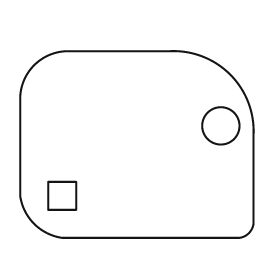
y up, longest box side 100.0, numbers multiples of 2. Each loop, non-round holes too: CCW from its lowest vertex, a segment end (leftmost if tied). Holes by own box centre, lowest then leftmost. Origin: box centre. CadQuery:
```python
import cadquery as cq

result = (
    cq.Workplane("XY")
    .moveTo(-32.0, -40.0)
    .lineTo(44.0, -40.0)
    .threePointArc((48.0, -38.0), (50.0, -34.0))
    .lineTo(50.0, 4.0)
    .threePointArc((40.0, 30.0), (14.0, 40.0))
    .lineTo(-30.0, 40.0)
    .threePointArc((-44.0, 34.0), (-50.0, 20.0))
    .lineTo(-50.0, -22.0)
    .threePointArc((-44.0, -34.0), (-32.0, -40.0))
    .close()
    .moveTo(-38.0, -28.0)
    .lineTo(-26.0, -28.0)
    .lineTo(-26.0, -16.0)
    .lineTo(-38.0, -16.0)
    .close()
    .moveTo(36.0, 8.0)
    .circle(8.0)
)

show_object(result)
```